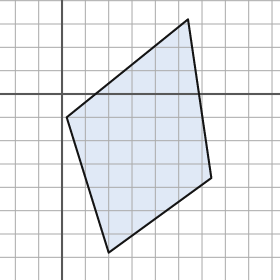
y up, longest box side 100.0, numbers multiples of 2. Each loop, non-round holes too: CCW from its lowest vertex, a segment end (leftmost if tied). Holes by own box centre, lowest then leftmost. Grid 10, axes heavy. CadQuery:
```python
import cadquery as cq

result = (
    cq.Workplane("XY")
    .moveTo(20.0, -68.0)
    .lineTo(64.0, -36.0)
    .lineTo(54.0, 32.0)
    .lineTo(2.0, -10.0)
    .close()
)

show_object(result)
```